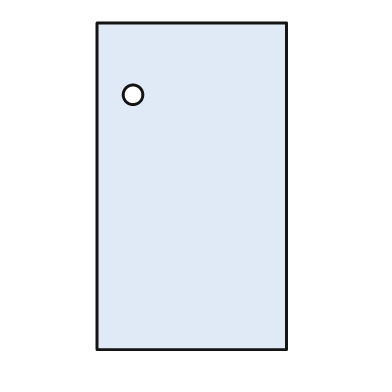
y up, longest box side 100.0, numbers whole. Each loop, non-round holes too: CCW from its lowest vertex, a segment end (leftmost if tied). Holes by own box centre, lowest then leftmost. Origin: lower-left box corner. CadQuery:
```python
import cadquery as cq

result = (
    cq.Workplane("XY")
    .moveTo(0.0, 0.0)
    .lineTo(58.0, 0.0)
    .lineTo(58.0, 100.0)
    .lineTo(0.0, 100.0)
    .close()
    .moveTo(11.0, 78.0)
    .circle(3.0)
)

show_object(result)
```